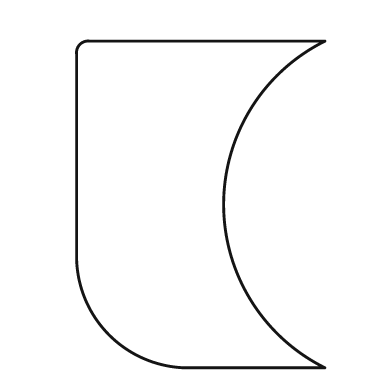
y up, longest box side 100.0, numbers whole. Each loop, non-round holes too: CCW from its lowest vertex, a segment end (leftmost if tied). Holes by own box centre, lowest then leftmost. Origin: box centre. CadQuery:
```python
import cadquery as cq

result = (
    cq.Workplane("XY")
    .moveTo(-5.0, -50.0)
    .lineTo(38.0, -50.0)
    .threePointArc((7.0, 0.0), (38.0, 50.0))
    .lineTo(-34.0, 50.0)
    .threePointArc((-37.0, 49.0), (-38.0, 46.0))
    .lineTo(-38.0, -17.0)
    .threePointArc((-28.0, -40.0), (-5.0, -50.0))
    .close()
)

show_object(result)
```